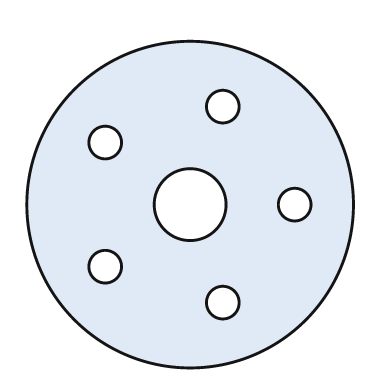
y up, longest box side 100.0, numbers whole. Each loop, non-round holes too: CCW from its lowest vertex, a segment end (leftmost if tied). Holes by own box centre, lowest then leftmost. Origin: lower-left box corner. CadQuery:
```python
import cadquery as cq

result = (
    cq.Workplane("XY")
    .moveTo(50.0, 50.0)
    .circle(50.0)
    .moveTo(60.0, 20.0)
    .circle(5.0)
    .moveTo(24.0, 31.0)
    .circle(5.0)
    .moveTo(50.0, 50.0)
    .circle(11.0)
    .moveTo(82.0, 50.0)
    .circle(5.0)
    .moveTo(24.0, 69.0)
    .circle(5.0)
    .moveTo(60.0, 80.0)
    .circle(5.0)
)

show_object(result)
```